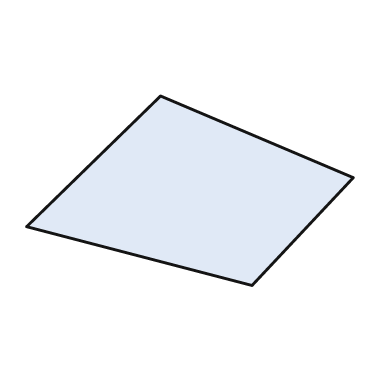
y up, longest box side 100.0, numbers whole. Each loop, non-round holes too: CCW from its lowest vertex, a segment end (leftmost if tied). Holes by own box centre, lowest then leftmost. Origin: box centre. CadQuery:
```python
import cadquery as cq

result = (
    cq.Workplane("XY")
    .moveTo(19.0, -29.0)
    .lineTo(50.0, 4.0)
    .lineTo(-9.0, 29.0)
    .lineTo(-50.0, -11.0)
    .close()
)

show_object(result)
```